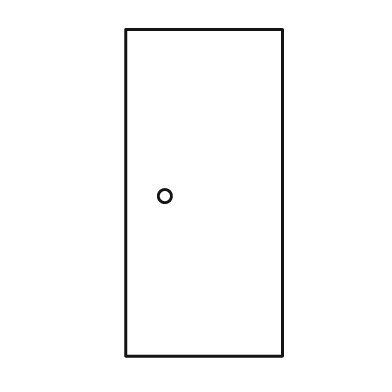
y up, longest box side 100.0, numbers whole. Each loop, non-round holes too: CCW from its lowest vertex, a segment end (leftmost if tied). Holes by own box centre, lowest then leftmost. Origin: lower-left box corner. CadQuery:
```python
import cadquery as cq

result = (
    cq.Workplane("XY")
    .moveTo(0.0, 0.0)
    .lineTo(48.0, 0.0)
    .lineTo(48.0, 100.0)
    .lineTo(0.0, 100.0)
    .close()
    .moveTo(12.0, 49.0)
    .circle(2.0)
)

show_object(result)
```